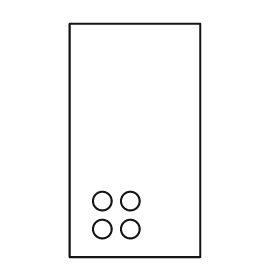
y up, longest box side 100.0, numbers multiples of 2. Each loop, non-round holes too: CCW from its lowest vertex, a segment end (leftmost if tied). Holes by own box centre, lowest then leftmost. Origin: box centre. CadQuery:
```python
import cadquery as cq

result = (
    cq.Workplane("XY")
    .moveTo(-28.0, -50.0)
    .lineTo(28.0, -50.0)
    .lineTo(28.0, 50.0)
    .lineTo(-28.0, 50.0)
    .close()
    .moveTo(-14.0, -38.0)
    .circle(4.0)
    .moveTo(-2.0, -38.0)
    .circle(4.0)
    .moveTo(-14.0, -26.0)
    .circle(4.0)
    .moveTo(-2.0, -26.0)
    .circle(4.0)
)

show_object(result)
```